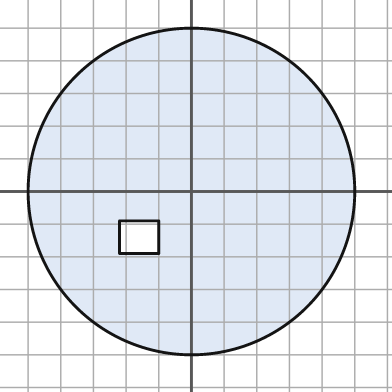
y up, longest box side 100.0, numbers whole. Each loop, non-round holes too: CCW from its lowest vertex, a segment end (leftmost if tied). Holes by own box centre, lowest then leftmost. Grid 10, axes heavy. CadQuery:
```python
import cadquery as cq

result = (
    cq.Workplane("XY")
    .moveTo(0.0, 0.0)
    .circle(50.0)
    .moveTo(-22.0, -19.0)
    .lineTo(-10.0, -19.0)
    .lineTo(-10.0, -9.0)
    .lineTo(-22.0, -9.0)
    .close()
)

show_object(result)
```